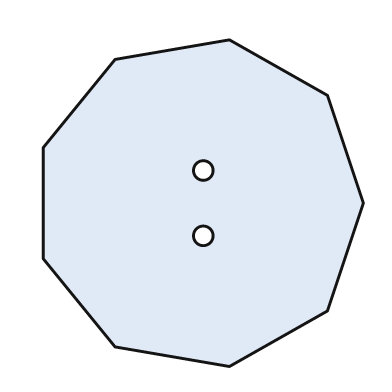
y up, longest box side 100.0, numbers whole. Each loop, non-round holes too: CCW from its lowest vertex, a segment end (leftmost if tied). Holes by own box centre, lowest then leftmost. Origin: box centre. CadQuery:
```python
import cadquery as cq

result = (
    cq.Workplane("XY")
    .moveTo(8.0, -50.0)
    .lineTo(38.0, -33.0)
    .lineTo(49.0, 0.0)
    .lineTo(38.0, 33.0)
    .lineTo(8.0, 50.0)
    .lineTo(-27.0, 44.0)
    .lineTo(-49.0, 17.0)
    .lineTo(-49.0, -17.0)
    .lineTo(-27.0, -44.0)
    .close()
    .moveTo(0.0, -10.0)
    .circle(3.0)
    .moveTo(0.0, 10.0)
    .circle(3.0)
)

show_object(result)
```